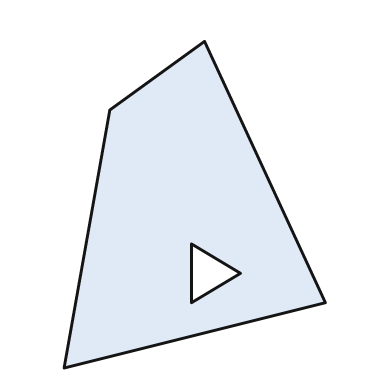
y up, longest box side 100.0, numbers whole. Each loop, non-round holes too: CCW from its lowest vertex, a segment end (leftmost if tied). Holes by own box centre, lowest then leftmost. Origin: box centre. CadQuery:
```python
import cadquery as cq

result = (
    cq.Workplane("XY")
    .moveTo(-40.0, -50.0)
    .lineTo(40.0, -30.0)
    .lineTo(3.0, 50.0)
    .lineTo(-26.0, 29.0)
    .close()
    .moveTo(-1.0, -30.0)
    .lineTo(14.0, -21.0)
    .lineTo(-1.0, -12.0)
    .close()
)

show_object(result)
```